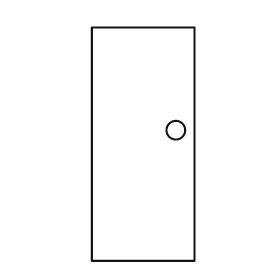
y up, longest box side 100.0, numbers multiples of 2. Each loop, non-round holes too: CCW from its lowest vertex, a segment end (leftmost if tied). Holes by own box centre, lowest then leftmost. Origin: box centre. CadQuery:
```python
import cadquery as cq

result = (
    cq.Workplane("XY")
    .moveTo(-22.0, -50.0)
    .lineTo(22.0, -50.0)
    .lineTo(22.0, 50.0)
    .lineTo(-22.0, 50.0)
    .close()
    .moveTo(14.0, 6.0)
    .circle(4.0)
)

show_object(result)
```